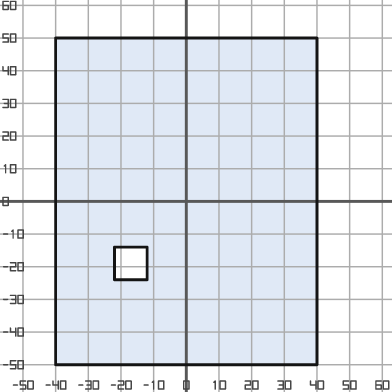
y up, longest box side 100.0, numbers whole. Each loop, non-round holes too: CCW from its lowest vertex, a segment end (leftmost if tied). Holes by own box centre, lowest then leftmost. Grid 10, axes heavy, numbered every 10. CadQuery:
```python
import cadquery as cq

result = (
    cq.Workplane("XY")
    .moveTo(-40.0, -50.0)
    .lineTo(40.0, -50.0)
    .lineTo(40.0, 50.0)
    .lineTo(-40.0, 50.0)
    .close()
    .moveTo(-22.0, -24.0)
    .lineTo(-12.0, -24.0)
    .lineTo(-12.0, -14.0)
    .lineTo(-22.0, -14.0)
    .close()
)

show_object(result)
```